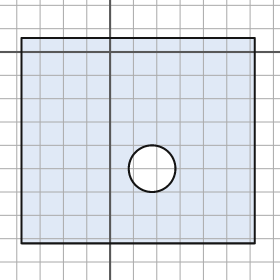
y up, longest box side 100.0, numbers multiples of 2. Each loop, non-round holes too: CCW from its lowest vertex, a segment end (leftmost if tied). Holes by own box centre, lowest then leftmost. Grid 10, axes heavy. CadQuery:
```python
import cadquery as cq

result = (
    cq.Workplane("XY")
    .moveTo(-38.0, -82.0)
    .lineTo(62.0, -82.0)
    .lineTo(62.0, 6.0)
    .lineTo(-38.0, 6.0)
    .close()
    .moveTo(18.0, -50.0)
    .circle(10.0)
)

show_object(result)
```